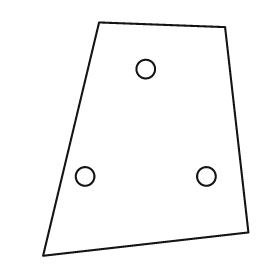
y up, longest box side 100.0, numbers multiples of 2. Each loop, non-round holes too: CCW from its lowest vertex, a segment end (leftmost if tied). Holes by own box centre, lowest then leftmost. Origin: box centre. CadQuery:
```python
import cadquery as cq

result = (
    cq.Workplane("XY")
    .moveTo(-44.0, -50.0)
    .lineTo(44.0, -40.0)
    .lineTo(34.0, 48.0)
    .lineTo(-20.0, 50.0)
    .close()
    .moveTo(-26.0, -16.0)
    .circle(4.0)
    .moveTo(26.0, -16.0)
    .circle(4.0)
    .moveTo(0.0, 30.0)
    .circle(4.0)
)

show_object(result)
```